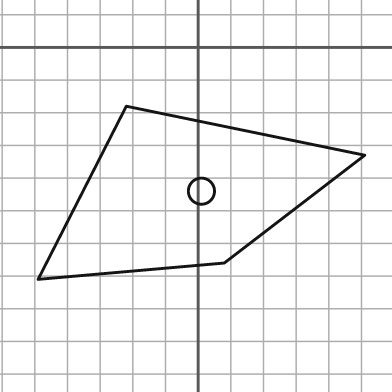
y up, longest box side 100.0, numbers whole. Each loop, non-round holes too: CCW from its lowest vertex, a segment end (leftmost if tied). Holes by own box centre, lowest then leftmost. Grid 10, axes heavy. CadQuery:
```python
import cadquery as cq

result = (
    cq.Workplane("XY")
    .moveTo(-49.0, -71.0)
    .lineTo(8.0, -66.0)
    .lineTo(51.0, -33.0)
    .lineTo(-22.0, -18.0)
    .close()
    .moveTo(1.0, -44.0)
    .circle(4.0)
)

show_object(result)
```